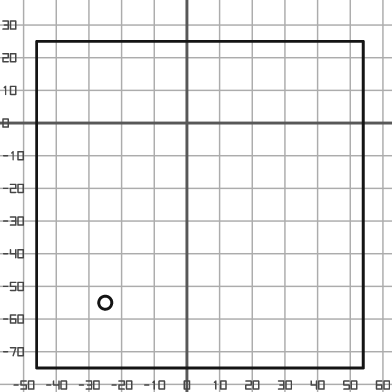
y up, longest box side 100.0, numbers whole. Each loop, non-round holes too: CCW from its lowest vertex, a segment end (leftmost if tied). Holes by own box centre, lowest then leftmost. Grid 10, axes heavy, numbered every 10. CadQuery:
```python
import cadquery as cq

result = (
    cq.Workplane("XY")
    .moveTo(-46.0, -75.0)
    .lineTo(54.0, -75.0)
    .lineTo(54.0, 25.0)
    .lineTo(-46.0, 25.0)
    .close()
    .moveTo(-25.0, -55.0)
    .circle(2.0)
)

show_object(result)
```